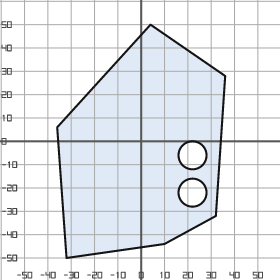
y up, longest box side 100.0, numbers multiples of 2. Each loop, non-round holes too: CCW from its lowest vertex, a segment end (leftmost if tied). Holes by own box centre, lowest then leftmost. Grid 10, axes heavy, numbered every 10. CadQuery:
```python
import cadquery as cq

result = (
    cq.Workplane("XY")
    .moveTo(-32.0, -50.0)
    .lineTo(10.0, -44.0)
    .lineTo(32.0, -32.0)
    .lineTo(36.0, 28.0)
    .lineTo(4.0, 50.0)
    .lineTo(-36.0, 6.0)
    .close()
    .moveTo(22.0, -22.0)
    .circle(6.0)
    .moveTo(22.0, -6.0)
    .circle(6.0)
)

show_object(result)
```